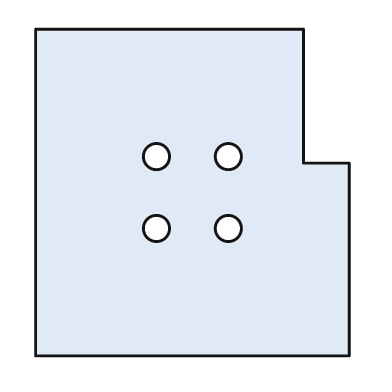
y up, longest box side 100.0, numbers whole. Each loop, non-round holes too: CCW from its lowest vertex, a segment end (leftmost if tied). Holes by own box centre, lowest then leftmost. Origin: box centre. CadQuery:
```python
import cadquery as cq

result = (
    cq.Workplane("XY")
    .moveTo(-48.0, -50.0)
    .lineTo(48.0, -50.0)
    .lineTo(48.0, 9.0)
    .lineTo(34.0, 9.0)
    .lineTo(34.0, 50.0)
    .lineTo(-48.0, 50.0)
    .close()
    .moveTo(-11.0, -11.0)
    .circle(4.0)
    .moveTo(11.0, -11.0)
    .circle(4.0)
    .moveTo(-11.0, 11.0)
    .circle(4.0)
    .moveTo(11.0, 11.0)
    .circle(4.0)
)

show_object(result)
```